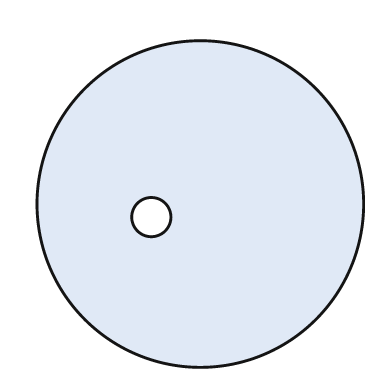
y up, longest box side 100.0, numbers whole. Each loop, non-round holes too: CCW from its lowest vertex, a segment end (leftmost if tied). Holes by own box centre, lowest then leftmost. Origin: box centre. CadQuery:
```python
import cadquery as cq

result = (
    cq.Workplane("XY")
    .moveTo(0.0, 0.0)
    .circle(50.0)
    .moveTo(-15.0, -4.0)
    .circle(6.0)
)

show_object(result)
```